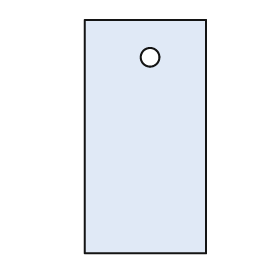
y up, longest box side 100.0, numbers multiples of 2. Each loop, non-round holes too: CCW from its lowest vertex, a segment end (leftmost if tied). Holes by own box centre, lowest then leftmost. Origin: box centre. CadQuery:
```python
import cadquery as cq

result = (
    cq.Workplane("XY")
    .moveTo(-26.0, -50.0)
    .lineTo(26.0, -50.0)
    .lineTo(26.0, 50.0)
    .lineTo(-26.0, 50.0)
    .close()
    .moveTo(2.0, 34.0)
    .circle(4.0)
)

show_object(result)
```